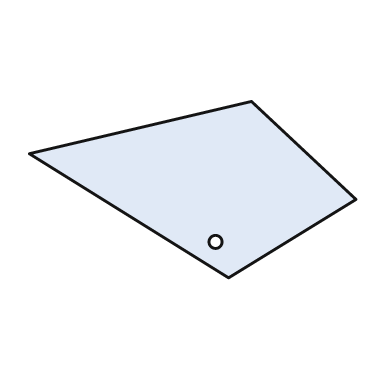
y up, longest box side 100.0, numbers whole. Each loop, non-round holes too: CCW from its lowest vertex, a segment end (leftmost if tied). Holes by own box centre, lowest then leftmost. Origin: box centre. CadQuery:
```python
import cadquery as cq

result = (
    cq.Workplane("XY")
    .moveTo(11.0, -27.0)
    .lineTo(50.0, -3.0)
    .lineTo(18.0, 27.0)
    .lineTo(-50.0, 11.0)
    .close()
    .moveTo(7.0, -16.0)
    .circle(2.0)
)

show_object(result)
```